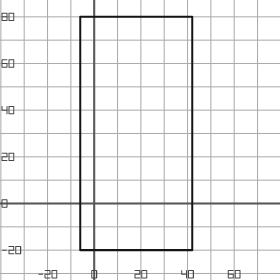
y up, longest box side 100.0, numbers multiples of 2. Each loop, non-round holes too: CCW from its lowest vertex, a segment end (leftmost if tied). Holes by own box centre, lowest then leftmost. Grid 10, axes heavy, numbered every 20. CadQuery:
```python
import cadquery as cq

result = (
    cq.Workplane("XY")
    .moveTo(-6.0, -20.0)
    .lineTo(42.0, -20.0)
    .lineTo(42.0, 80.0)
    .lineTo(-6.0, 80.0)
    .close()
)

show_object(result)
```